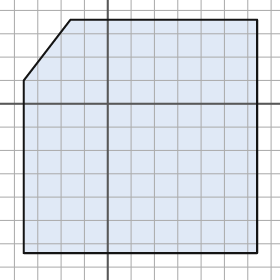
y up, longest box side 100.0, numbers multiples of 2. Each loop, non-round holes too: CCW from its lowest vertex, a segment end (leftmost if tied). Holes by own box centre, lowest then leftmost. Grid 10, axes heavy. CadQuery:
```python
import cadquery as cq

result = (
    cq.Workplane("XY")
    .moveTo(-36.0, -64.0)
    .lineTo(64.0, -64.0)
    .lineTo(64.0, 36.0)
    .lineTo(-16.0, 36.0)
    .lineTo(-36.0, 10.0)
    .close()
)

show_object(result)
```